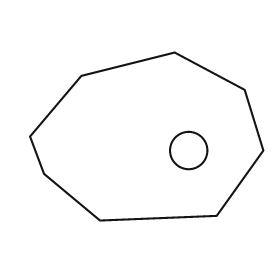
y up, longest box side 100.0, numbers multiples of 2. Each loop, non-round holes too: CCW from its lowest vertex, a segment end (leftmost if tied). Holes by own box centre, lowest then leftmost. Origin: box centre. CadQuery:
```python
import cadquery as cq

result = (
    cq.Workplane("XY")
    .moveTo(-20.0, -36.0)
    .lineTo(30.0, -34.0)
    .lineTo(50.0, -6.0)
    .lineTo(42.0, 20.0)
    .lineTo(12.0, 36.0)
    .lineTo(-28.0, 26.0)
    .lineTo(-50.0, 0.0)
    .lineTo(-44.0, -16.0)
    .close()
    .moveTo(18.0, -6.0)
    .circle(8.0)
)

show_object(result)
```